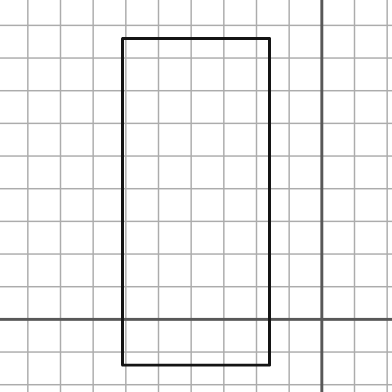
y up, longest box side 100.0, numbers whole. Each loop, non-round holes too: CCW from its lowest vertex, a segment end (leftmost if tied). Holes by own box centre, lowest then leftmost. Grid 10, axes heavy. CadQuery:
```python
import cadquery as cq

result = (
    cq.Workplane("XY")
    .moveTo(-61.0, -14.0)
    .lineTo(-16.0, -14.0)
    .lineTo(-16.0, 86.0)
    .lineTo(-61.0, 86.0)
    .close()
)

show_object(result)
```